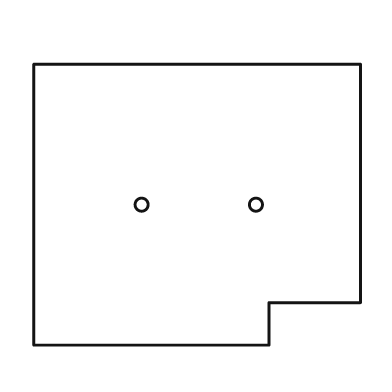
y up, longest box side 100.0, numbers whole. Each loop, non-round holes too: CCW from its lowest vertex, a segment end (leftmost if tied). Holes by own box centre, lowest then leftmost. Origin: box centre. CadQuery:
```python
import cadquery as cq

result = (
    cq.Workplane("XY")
    .moveTo(-50.0, -43.0)
    .lineTo(22.0, -43.0)
    .lineTo(22.0, -30.0)
    .lineTo(50.0, -30.0)
    .lineTo(50.0, 43.0)
    .lineTo(-50.0, 43.0)
    .close()
    .moveTo(-17.0, 0.0)
    .circle(2.0)
    .moveTo(18.0, 0.0)
    .circle(2.0)
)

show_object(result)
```